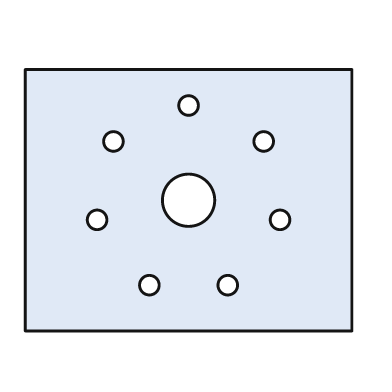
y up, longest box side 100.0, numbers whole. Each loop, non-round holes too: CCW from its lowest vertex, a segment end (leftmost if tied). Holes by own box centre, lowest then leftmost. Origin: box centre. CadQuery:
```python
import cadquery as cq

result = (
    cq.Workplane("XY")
    .moveTo(-50.0, -40.0)
    .lineTo(50.0, -40.0)
    .lineTo(50.0, 40.0)
    .lineTo(-50.0, 40.0)
    .close()
    .moveTo(-12.0, -26.0)
    .circle(3.0)
    .moveTo(12.0, -26.0)
    .circle(3.0)
    .moveTo(-28.0, -6.0)
    .circle(3.0)
    .moveTo(28.0, -6.0)
    .circle(3.0)
    .moveTo(0.0, 0.0)
    .circle(8.0)
    .moveTo(-23.0, 18.0)
    .circle(3.0)
    .moveTo(23.0, 18.0)
    .circle(3.0)
    .moveTo(0.0, 29.0)
    .circle(3.0)
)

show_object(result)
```